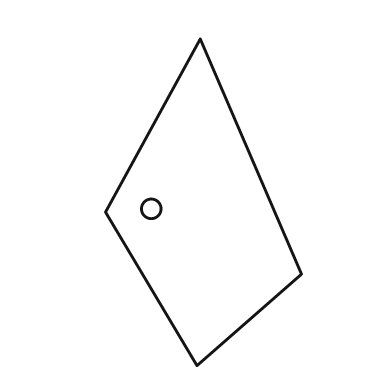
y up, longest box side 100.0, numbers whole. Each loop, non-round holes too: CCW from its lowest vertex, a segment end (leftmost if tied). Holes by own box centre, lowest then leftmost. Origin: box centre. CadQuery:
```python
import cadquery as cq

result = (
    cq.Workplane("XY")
    .moveTo(-2.0, -50.0)
    .lineTo(30.0, -22.0)
    .lineTo(-1.0, 50.0)
    .lineTo(-30.0, -3.0)
    .close()
    .moveTo(-16.0, -2.0)
    .circle(3.0)
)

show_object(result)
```